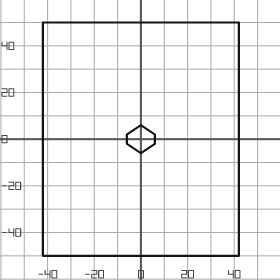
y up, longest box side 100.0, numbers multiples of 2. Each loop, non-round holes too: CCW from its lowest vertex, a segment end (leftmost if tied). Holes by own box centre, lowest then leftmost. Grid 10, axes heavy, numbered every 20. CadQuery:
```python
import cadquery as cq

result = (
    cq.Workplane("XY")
    .moveTo(-42.0, -50.0)
    .lineTo(42.0, -50.0)
    .lineTo(42.0, 50.0)
    .lineTo(-42.0, 50.0)
    .close()
    .moveTo(0.0, -6.0)
    .lineTo(6.0, -2.0)
    .lineTo(6.0, 2.0)
    .lineTo(0.0, 6.0)
    .lineTo(-6.0, 2.0)
    .lineTo(-6.0, -2.0)
    .close()
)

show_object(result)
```